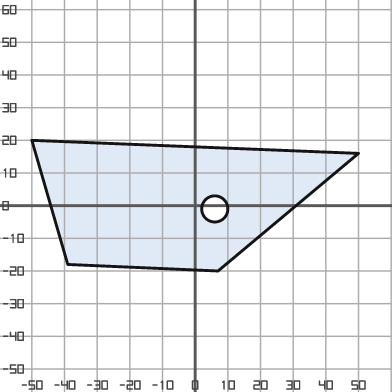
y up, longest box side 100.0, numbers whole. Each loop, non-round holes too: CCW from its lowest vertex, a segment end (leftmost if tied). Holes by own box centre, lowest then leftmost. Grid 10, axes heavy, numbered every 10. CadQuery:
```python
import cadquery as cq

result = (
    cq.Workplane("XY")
    .moveTo(7.0, -20.0)
    .lineTo(50.0, 16.0)
    .lineTo(-50.0, 20.0)
    .lineTo(-39.0, -18.0)
    .close()
    .moveTo(6.0, -1.0)
    .circle(4.0)
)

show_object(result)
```